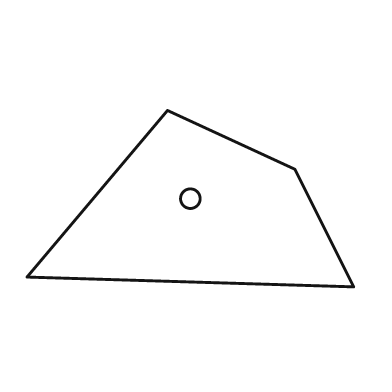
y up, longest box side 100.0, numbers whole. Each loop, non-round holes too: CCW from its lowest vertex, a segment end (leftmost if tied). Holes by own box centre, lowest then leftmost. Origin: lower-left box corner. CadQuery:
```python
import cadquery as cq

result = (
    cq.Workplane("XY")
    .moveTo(100.0, 0.0)
    .lineTo(82.0, 36.0)
    .lineTo(43.0, 54.0)
    .lineTo(0.0, 3.0)
    .close()
    .moveTo(50.0, 27.0)
    .circle(3.0)
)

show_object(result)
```